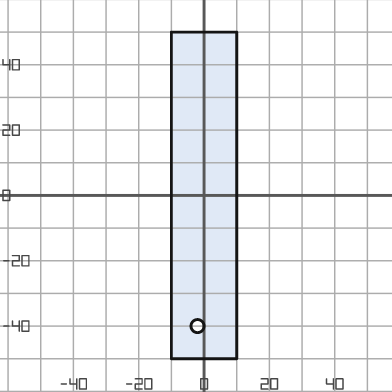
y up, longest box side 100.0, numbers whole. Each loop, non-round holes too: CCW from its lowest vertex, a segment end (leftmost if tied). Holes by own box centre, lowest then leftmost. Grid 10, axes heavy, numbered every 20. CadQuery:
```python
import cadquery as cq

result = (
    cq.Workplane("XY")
    .moveTo(-10.0, -50.0)
    .lineTo(10.0, -50.0)
    .lineTo(10.0, 50.0)
    .lineTo(-10.0, 50.0)
    .close()
    .moveTo(-2.0, -40.0)
    .circle(2.0)
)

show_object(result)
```